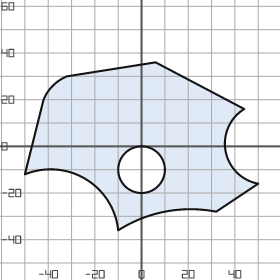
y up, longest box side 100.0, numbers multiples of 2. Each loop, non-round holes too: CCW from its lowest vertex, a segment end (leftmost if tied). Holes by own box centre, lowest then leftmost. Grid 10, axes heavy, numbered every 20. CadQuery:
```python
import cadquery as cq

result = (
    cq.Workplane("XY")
    .moveTo(-10.0, -36.0)
    .threePointArc((10.0, -28.0), (32.0, -28.0))
    .lineTo(50.0, -16.0)
    .threePointArc((36.0, -2.0), (44.0, 16.0))
    .lineTo(6.0, 36.0)
    .lineTo(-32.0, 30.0)
    .threePointArc((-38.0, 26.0), (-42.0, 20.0))
    .lineTo(-50.0, -12.0)
    .threePointArc((-24.0, -14.0), (-10.0, -36.0))
    .close()
    .moveTo(0.0, -10.0)
    .circle(10.0)
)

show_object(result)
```